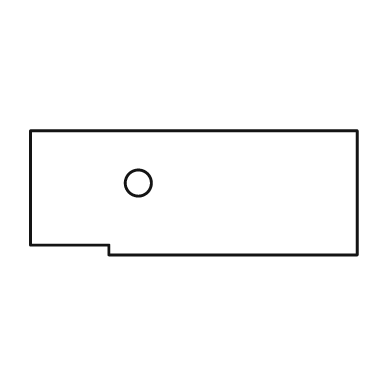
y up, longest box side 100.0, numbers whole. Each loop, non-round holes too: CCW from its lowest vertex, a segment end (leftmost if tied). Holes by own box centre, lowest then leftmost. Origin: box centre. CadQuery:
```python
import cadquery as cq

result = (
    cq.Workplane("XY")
    .moveTo(-26.0, -19.0)
    .lineTo(50.0, -19.0)
    .lineTo(50.0, 19.0)
    .lineTo(-50.0, 19.0)
    .lineTo(-50.0, -16.0)
    .lineTo(-26.0, -16.0)
    .close()
    .moveTo(-17.0, 3.0)
    .circle(4.0)
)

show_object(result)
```